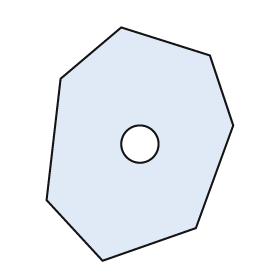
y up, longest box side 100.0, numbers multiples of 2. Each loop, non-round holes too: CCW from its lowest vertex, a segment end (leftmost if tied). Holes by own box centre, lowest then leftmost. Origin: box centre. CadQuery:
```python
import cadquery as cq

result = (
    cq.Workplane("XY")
    .moveTo(-16.0, -50.0)
    .lineTo(24.0, -36.0)
    .lineTo(40.0, 8.0)
    .lineTo(30.0, 38.0)
    .lineTo(-8.0, 50.0)
    .lineTo(-34.0, 28.0)
    .lineTo(-40.0, -24.0)
    .close()
    .moveTo(0.0, 0.0)
    .circle(8.0)
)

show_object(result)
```